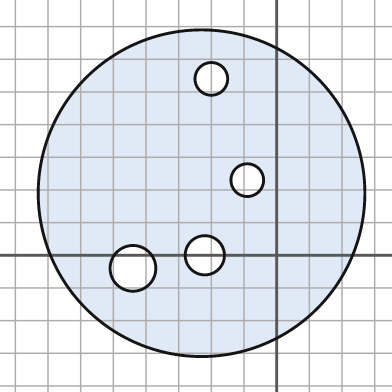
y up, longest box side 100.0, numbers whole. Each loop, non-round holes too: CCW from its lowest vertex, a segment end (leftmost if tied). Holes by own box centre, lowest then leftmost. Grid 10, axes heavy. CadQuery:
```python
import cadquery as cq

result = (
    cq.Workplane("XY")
    .moveTo(-23.0, 19.0)
    .circle(50.0)
    .moveTo(-44.0, -4.0)
    .circle(7.0)
    .moveTo(-22.0, 0.0)
    .circle(6.0)
    .moveTo(-9.0, 23.0)
    .circle(5.0)
    .moveTo(-20.0, 54.0)
    .circle(5.0)
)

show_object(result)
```